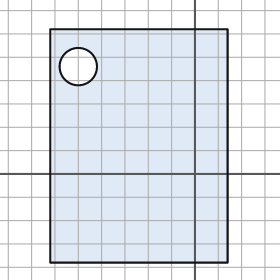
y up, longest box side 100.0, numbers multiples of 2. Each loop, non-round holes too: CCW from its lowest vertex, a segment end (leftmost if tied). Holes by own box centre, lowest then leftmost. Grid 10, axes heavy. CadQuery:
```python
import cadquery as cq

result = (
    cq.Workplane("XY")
    .moveTo(-62.0, -38.0)
    .lineTo(14.0, -38.0)
    .lineTo(14.0, 62.0)
    .lineTo(-62.0, 62.0)
    .close()
    .moveTo(-50.0, 46.0)
    .circle(8.0)
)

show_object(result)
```